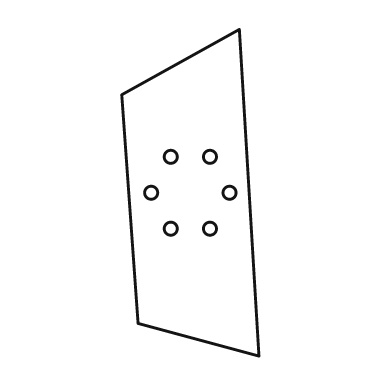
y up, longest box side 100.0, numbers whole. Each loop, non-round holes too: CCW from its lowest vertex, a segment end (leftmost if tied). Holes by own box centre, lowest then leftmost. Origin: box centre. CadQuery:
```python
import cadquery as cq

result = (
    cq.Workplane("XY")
    .moveTo(21.0, -50.0)
    .lineTo(15.0, 50.0)
    .lineTo(-21.0, 30.0)
    .lineTo(-16.0, -40.0)
    .close()
    .moveTo(-6.0, -11.0)
    .circle(2.0)
    .moveTo(6.0, -11.0)
    .circle(2.0)
    .moveTo(-12.0, 0.0)
    .circle(2.0)
    .moveTo(12.0, 0.0)
    .circle(2.0)
    .moveTo(-6.0, 11.0)
    .circle(2.0)
    .moveTo(6.0, 11.0)
    .circle(2.0)
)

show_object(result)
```